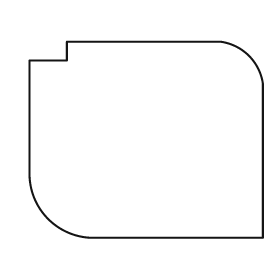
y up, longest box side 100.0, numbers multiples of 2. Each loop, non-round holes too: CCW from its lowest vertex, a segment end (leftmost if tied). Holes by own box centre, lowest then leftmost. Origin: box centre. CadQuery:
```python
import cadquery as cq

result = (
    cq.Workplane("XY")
    .moveTo(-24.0, -42.0)
    .lineTo(50.0, -42.0)
    .lineTo(50.0, 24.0)
    .threePointArc((44.0, 36.0), (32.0, 42.0))
    .lineTo(-34.0, 42.0)
    .lineTo(-34.0, 34.0)
    .lineTo(-50.0, 34.0)
    .lineTo(-50.0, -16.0)
    .threePointArc((-42.0, -34.0), (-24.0, -42.0))
    .close()
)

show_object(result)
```